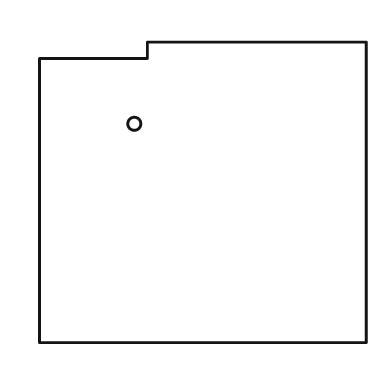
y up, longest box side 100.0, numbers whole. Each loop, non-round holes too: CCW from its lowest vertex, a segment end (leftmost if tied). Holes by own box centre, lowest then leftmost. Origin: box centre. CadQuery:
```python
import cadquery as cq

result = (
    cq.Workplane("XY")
    .moveTo(-50.0, -46.0)
    .lineTo(50.0, -46.0)
    .lineTo(50.0, 46.0)
    .lineTo(-17.0, 46.0)
    .lineTo(-17.0, 41.0)
    .lineTo(-50.0, 41.0)
    .close()
    .moveTo(-21.0, 21.0)
    .circle(2.0)
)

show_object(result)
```